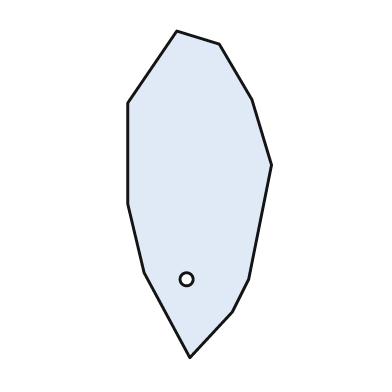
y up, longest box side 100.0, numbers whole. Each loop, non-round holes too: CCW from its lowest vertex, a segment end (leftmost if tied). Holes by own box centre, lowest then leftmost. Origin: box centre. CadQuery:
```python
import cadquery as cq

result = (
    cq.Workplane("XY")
    .moveTo(-3.0, -50.0)
    .lineTo(10.0, -36.0)
    .lineTo(15.0, -26.0)
    .lineTo(22.0, 9.0)
    .lineTo(16.0, 29.0)
    .lineTo(6.0, 46.0)
    .lineTo(-7.0, 50.0)
    .lineTo(-22.0, 28.0)
    .lineTo(-22.0, -3.0)
    .lineTo(-17.0, -24.0)
    .close()
    .moveTo(-4.0, -26.0)
    .circle(2.0)
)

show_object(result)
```